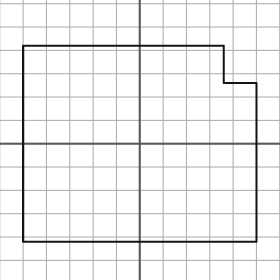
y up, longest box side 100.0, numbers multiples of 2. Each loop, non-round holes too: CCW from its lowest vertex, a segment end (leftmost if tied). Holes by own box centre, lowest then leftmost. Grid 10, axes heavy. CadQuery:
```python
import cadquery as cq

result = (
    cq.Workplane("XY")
    .moveTo(-50.0, -42.0)
    .lineTo(50.0, -42.0)
    .lineTo(50.0, 26.0)
    .lineTo(36.0, 26.0)
    .lineTo(36.0, 42.0)
    .lineTo(-50.0, 42.0)
    .close()
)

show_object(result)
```